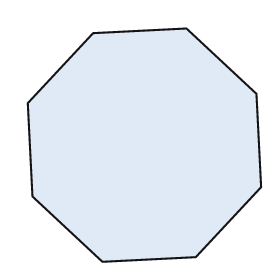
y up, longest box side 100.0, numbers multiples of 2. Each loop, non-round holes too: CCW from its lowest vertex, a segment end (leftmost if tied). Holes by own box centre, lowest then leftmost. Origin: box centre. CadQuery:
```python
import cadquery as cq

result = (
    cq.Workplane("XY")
    .moveTo(-18.0, -50.0)
    .lineTo(22.0, -48.0)
    .lineTo(50.0, -18.0)
    .lineTo(48.0, 22.0)
    .lineTo(18.0, 50.0)
    .lineTo(-22.0, 48.0)
    .lineTo(-50.0, 18.0)
    .lineTo(-48.0, -22.0)
    .close()
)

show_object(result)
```